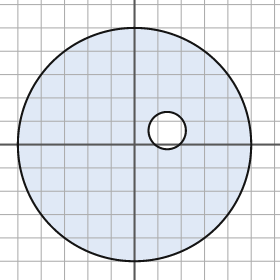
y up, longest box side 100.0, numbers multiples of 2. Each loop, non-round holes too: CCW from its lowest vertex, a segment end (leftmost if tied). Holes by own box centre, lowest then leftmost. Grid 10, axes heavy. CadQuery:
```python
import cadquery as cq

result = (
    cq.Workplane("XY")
    .moveTo(0.0, 0.0)
    .circle(50.0)
    .moveTo(14.0, 6.0)
    .circle(8.0)
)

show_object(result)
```